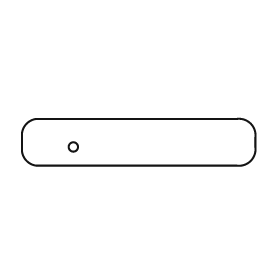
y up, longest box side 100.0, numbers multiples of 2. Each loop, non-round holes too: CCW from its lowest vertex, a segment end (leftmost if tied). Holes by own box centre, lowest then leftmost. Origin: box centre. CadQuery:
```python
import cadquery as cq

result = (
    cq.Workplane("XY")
    .moveTo(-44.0, -10.0)
    .lineTo(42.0, -10.0)
    .threePointArc((48.0, -8.0), (50.0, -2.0))
    .lineTo(50.0, 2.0)
    .threePointArc((48.0, 8.0), (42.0, 10.0))
    .lineTo(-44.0, 10.0)
    .threePointArc((-48.0, 8.0), (-50.0, 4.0))
    .lineTo(-50.0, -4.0)
    .threePointArc((-48.0, -8.0), (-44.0, -10.0))
    .close()
    .moveTo(-28.0, -2.0)
    .circle(2.0)
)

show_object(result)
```